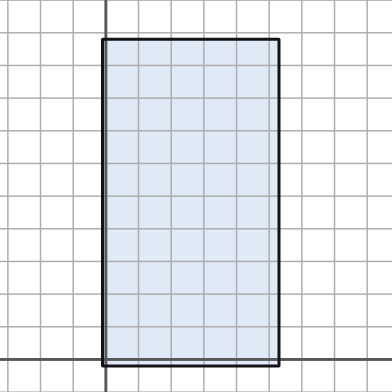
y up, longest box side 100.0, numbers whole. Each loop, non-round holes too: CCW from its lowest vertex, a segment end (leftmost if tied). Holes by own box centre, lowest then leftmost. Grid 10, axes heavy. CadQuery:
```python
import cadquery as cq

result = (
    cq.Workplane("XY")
    .moveTo(-1.0, -2.0)
    .lineTo(53.0, -2.0)
    .lineTo(53.0, 98.0)
    .lineTo(-1.0, 98.0)
    .close()
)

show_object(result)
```